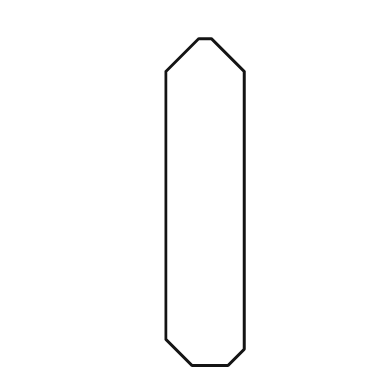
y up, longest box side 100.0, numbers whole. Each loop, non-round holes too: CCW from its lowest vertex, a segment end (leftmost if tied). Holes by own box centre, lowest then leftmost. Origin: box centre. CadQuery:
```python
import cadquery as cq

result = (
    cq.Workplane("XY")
    .moveTo(-4.0, -50.0)
    .lineTo(7.0, -50.0)
    .lineTo(12.0, -45.0)
    .lineTo(12.0, 40.0)
    .lineTo(2.0, 50.0)
    .lineTo(-2.0, 50.0)
    .lineTo(-12.0, 40.0)
    .lineTo(-12.0, -42.0)
    .close()
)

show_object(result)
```